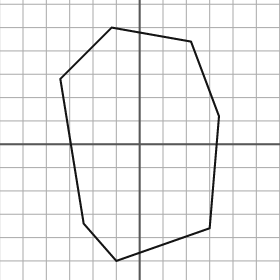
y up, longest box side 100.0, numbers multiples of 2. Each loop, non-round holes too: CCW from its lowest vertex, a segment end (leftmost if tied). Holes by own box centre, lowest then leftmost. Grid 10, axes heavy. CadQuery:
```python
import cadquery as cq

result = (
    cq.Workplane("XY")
    .moveTo(-10.0, -50.0)
    .lineTo(30.0, -36.0)
    .lineTo(34.0, 12.0)
    .lineTo(22.0, 44.0)
    .lineTo(-12.0, 50.0)
    .lineTo(-34.0, 28.0)
    .lineTo(-24.0, -34.0)
    .close()
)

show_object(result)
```